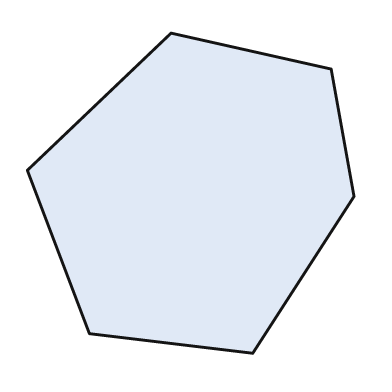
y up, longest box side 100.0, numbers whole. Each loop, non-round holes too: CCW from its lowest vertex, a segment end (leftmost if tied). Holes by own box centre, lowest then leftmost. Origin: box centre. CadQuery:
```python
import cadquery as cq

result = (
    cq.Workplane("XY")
    .moveTo(19.0, -49.0)
    .lineTo(50.0, -1.0)
    .lineTo(43.0, 38.0)
    .lineTo(-6.0, 49.0)
    .lineTo(-50.0, 7.0)
    .lineTo(-31.0, -43.0)
    .close()
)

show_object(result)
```